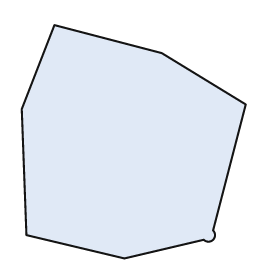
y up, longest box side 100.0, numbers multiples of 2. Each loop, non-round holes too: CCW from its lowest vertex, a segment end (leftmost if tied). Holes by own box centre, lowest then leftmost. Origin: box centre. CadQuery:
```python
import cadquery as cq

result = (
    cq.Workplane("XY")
    .moveTo(-4.0, -50.0)
    .lineTo(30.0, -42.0)
    .threePointArc((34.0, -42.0), (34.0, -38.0))
    .lineTo(48.0, 16.0)
    .lineTo(12.0, 38.0)
    .lineTo(-34.0, 50.0)
    .lineTo(-48.0, 14.0)
    .lineTo(-46.0, -40.0)
    .close()
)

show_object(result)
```